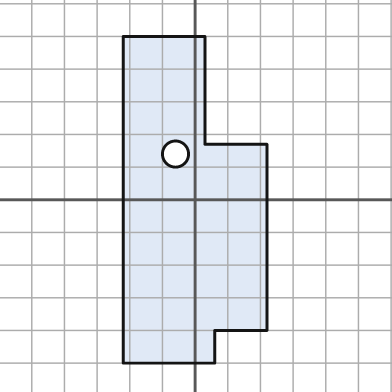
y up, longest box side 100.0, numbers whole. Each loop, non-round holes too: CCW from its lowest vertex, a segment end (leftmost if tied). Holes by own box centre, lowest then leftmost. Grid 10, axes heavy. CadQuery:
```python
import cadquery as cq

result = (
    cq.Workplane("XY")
    .moveTo(-22.0, -50.0)
    .lineTo(6.0, -50.0)
    .lineTo(6.0, -40.0)
    .lineTo(22.0, -40.0)
    .lineTo(22.0, 17.0)
    .lineTo(3.0, 17.0)
    .lineTo(3.0, 50.0)
    .lineTo(-22.0, 50.0)
    .close()
    .moveTo(-6.0, 14.0)
    .circle(4.0)
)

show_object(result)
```